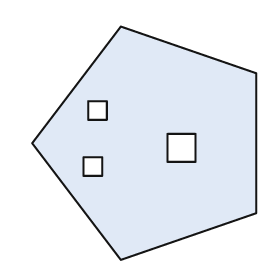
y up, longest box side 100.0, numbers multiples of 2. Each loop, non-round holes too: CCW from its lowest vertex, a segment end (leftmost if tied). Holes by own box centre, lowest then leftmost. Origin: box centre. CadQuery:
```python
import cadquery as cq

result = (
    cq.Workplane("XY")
    .moveTo(-10.0, -50.0)
    .lineTo(48.0, -30.0)
    .lineTo(48.0, 30.0)
    .lineTo(-10.0, 50.0)
    .lineTo(-48.0, 0.0)
    .close()
    .moveTo(-26.0, -14.0)
    .lineTo(-18.0, -14.0)
    .lineTo(-18.0, -6.0)
    .lineTo(-26.0, -6.0)
    .close()
    .moveTo(10.0, -8.0)
    .lineTo(22.0, -8.0)
    .lineTo(22.0, 4.0)
    .lineTo(10.0, 4.0)
    .close()
    .moveTo(-24.0, 10.0)
    .lineTo(-16.0, 10.0)
    .lineTo(-16.0, 18.0)
    .lineTo(-24.0, 18.0)
    .close()
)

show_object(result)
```